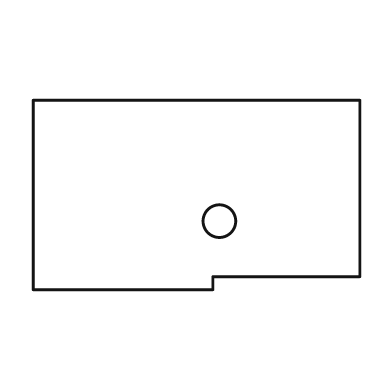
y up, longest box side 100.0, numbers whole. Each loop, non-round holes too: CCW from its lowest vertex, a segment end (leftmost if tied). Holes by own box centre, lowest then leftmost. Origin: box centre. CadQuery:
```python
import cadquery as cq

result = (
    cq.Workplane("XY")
    .moveTo(-50.0, -29.0)
    .lineTo(5.0, -29.0)
    .lineTo(5.0, -25.0)
    .lineTo(50.0, -25.0)
    .lineTo(50.0, 29.0)
    .lineTo(-50.0, 29.0)
    .close()
    .moveTo(7.0, -8.0)
    .circle(5.0)
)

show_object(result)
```